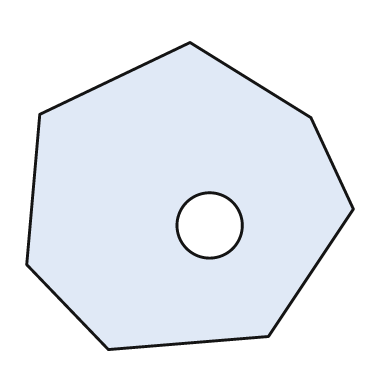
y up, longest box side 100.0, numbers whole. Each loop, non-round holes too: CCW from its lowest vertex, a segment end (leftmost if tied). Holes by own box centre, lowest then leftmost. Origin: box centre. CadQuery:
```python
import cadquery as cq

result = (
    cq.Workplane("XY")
    .moveTo(-25.0, -47.0)
    .lineTo(24.0, -43.0)
    .lineTo(50.0, -4.0)
    .lineTo(37.0, 24.0)
    .lineTo(0.0, 47.0)
    .lineTo(-46.0, 25.0)
    .lineTo(-50.0, -21.0)
    .close()
    .moveTo(6.0, -9.0)
    .circle(10.0)
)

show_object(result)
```